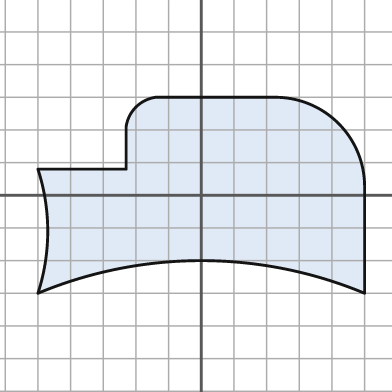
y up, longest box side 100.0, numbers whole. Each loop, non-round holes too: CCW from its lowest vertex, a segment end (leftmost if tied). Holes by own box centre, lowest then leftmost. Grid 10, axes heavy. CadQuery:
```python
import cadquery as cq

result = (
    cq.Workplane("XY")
    .moveTo(-50.0, -30.0)
    .threePointArc((0.0, -20.0), (50.0, -30.0))
    .lineTo(50.0, 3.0)
    .threePointArc((42.0, 22.0), (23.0, 30.0))
    .lineTo(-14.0, 30.0)
    .threePointArc((-20.0, 27.0), (-23.0, 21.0))
    .lineTo(-23.0, 8.0)
    .lineTo(-50.0, 8.0)
    .threePointArc((-47.0, -11.0), (-50.0, -30.0))
    .close()
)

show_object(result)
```